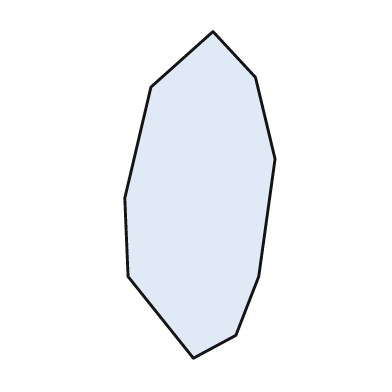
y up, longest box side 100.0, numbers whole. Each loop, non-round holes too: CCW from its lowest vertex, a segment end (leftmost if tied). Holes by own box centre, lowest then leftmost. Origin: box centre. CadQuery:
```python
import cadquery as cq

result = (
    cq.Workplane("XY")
    .moveTo(-2.0, -50.0)
    .lineTo(11.0, -43.0)
    .lineTo(18.0, -25.0)
    .lineTo(23.0, 11.0)
    .lineTo(17.0, 36.0)
    .lineTo(4.0, 50.0)
    .lineTo(-15.0, 33.0)
    .lineTo(-23.0, -1.0)
    .lineTo(-22.0, -25.0)
    .close()
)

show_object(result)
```